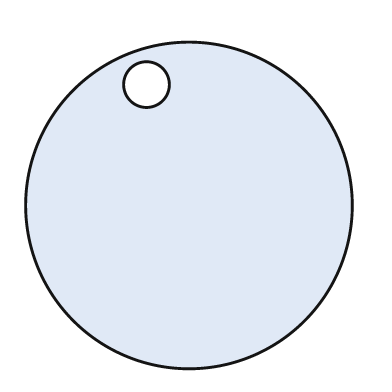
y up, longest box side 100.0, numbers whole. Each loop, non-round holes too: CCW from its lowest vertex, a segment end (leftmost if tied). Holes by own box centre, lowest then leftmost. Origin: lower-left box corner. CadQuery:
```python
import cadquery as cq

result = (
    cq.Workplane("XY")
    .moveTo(50.0, 50.0)
    .circle(50.0)
    .moveTo(37.0, 87.0)
    .circle(7.0)
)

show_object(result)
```